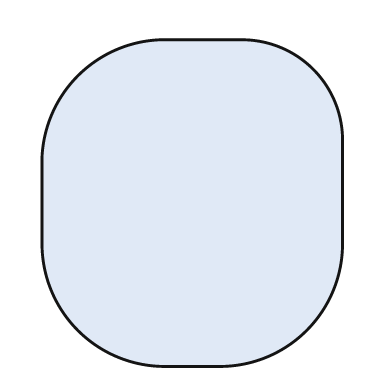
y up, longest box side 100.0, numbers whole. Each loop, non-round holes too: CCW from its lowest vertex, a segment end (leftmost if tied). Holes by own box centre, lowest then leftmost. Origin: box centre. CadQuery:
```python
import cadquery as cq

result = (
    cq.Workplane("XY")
    .moveTo(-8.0, -50.0)
    .lineTo(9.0, -50.0)
    .threePointArc((35.0, -39.0), (46.0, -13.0))
    .lineTo(46.0, 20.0)
    .threePointArc((37.0, 41.0), (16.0, 50.0))
    .lineTo(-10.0, 50.0)
    .threePointArc((-35.0, 39.0), (-46.0, 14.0))
    .lineTo(-46.0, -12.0)
    .threePointArc((-35.0, -39.0), (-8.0, -50.0))
    .close()
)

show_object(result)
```